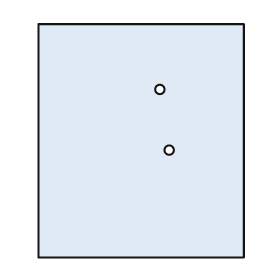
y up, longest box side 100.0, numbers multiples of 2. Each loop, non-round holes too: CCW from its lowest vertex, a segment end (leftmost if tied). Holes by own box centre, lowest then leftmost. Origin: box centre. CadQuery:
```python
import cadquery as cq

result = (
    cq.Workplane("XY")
    .moveTo(-44.0, -50.0)
    .lineTo(44.0, -50.0)
    .lineTo(44.0, 50.0)
    .lineTo(-44.0, 50.0)
    .close()
    .moveTo(12.0, -4.0)
    .circle(2.0)
    .moveTo(8.0, 22.0)
    .circle(2.0)
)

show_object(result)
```